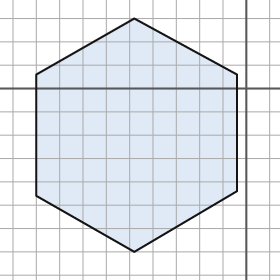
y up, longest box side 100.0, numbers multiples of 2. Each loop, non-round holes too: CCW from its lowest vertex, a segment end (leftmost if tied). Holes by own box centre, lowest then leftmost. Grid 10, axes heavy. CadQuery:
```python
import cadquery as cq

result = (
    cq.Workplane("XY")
    .moveTo(-48.0, -70.0)
    .lineTo(-4.0, -44.0)
    .lineTo(-4.0, 6.0)
    .lineTo(-48.0, 30.0)
    .lineTo(-90.0, 6.0)
    .lineTo(-90.0, -46.0)
    .close()
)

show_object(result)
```